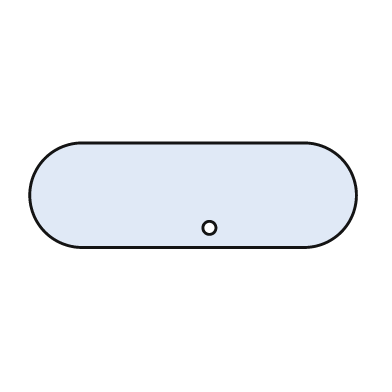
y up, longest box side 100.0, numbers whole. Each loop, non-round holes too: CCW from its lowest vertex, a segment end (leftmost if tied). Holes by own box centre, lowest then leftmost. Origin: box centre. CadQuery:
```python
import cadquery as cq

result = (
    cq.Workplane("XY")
    .moveTo(-34.0, -16.0)
    .lineTo(34.0, -16.0)
    .threePointArc((50.0, 0.0), (34.0, 16.0))
    .lineTo(-34.0, 16.0)
    .threePointArc((-50.0, 0.0), (-34.0, -16.0))
    .close()
    .moveTo(5.0, -10.0)
    .circle(2.0)
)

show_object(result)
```